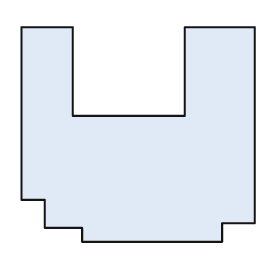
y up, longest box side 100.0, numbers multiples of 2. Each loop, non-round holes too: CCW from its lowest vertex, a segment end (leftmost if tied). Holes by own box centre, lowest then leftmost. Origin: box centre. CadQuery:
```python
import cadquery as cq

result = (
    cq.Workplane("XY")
    .moveTo(-24.0, -46.0)
    .lineTo(36.0, -46.0)
    .lineTo(36.0, -38.0)
    .lineTo(50.0, -38.0)
    .lineTo(50.0, 46.0)
    .lineTo(20.0, 46.0)
    .lineTo(20.0, 8.0)
    .lineTo(-28.0, 8.0)
    .lineTo(-28.0, 46.0)
    .lineTo(-50.0, 46.0)
    .lineTo(-50.0, -28.0)
    .lineTo(-40.0, -28.0)
    .lineTo(-40.0, -40.0)
    .lineTo(-24.0, -40.0)
    .close()
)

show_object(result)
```